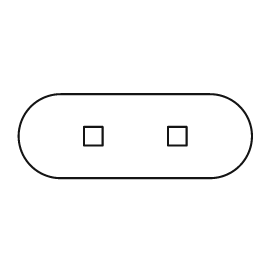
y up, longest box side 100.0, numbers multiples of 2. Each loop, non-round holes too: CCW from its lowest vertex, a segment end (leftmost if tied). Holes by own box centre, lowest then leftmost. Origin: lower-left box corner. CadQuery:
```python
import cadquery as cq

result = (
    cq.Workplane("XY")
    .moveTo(18.0, 0.0)
    .lineTo(82.0, 0.0)
    .threePointArc((100.0, 18.0), (82.0, 36.0))
    .lineTo(18.0, 36.0)
    .threePointArc((0.0, 18.0), (18.0, 0.0))
    .close()
    .moveTo(28.0, 14.0)
    .lineTo(36.0, 14.0)
    .lineTo(36.0, 22.0)
    .lineTo(28.0, 22.0)
    .close()
    .moveTo(64.0, 14.0)
    .lineTo(72.0, 14.0)
    .lineTo(72.0, 22.0)
    .lineTo(64.0, 22.0)
    .close()
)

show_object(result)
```